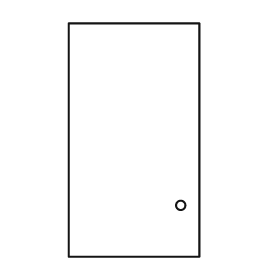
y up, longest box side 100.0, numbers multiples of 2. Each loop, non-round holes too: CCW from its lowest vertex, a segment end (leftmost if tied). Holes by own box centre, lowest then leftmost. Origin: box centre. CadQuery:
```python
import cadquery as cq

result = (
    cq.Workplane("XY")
    .moveTo(-28.0, -50.0)
    .lineTo(28.0, -50.0)
    .lineTo(28.0, 50.0)
    .lineTo(-28.0, 50.0)
    .close()
    .moveTo(20.0, -28.0)
    .circle(2.0)
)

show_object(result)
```